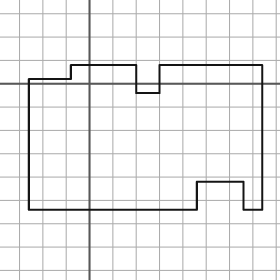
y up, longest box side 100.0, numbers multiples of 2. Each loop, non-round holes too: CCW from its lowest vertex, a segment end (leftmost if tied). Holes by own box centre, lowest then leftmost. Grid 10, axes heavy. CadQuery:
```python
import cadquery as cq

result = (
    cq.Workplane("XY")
    .moveTo(-26.0, -54.0)
    .lineTo(46.0, -54.0)
    .lineTo(46.0, -42.0)
    .lineTo(66.0, -42.0)
    .lineTo(66.0, -54.0)
    .lineTo(74.0, -54.0)
    .lineTo(74.0, 8.0)
    .lineTo(30.0, 8.0)
    .lineTo(30.0, -4.0)
    .lineTo(20.0, -4.0)
    .lineTo(20.0, 8.0)
    .lineTo(-8.0, 8.0)
    .lineTo(-8.0, 2.0)
    .lineTo(-26.0, 2.0)
    .close()
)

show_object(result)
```